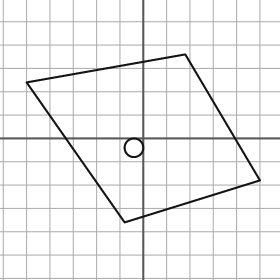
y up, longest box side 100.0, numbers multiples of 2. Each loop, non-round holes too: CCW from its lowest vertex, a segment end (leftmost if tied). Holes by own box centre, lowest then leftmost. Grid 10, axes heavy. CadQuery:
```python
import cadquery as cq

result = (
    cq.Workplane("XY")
    .moveTo(-8.0, -36.0)
    .lineTo(50.0, -18.0)
    .lineTo(18.0, 36.0)
    .lineTo(-50.0, 24.0)
    .close()
    .moveTo(-4.0, -4.0)
    .circle(4.0)
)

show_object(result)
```